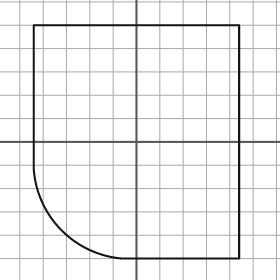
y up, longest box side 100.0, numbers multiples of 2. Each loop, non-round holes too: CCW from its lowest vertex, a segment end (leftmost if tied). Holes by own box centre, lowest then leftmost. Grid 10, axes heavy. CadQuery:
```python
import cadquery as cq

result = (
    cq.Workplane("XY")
    .moveTo(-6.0, -50.0)
    .lineTo(44.0, -50.0)
    .lineTo(44.0, 50.0)
    .lineTo(-44.0, 50.0)
    .lineTo(-44.0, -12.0)
    .threePointArc((-32.0, -38.0), (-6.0, -50.0))
    .close()
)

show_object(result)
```